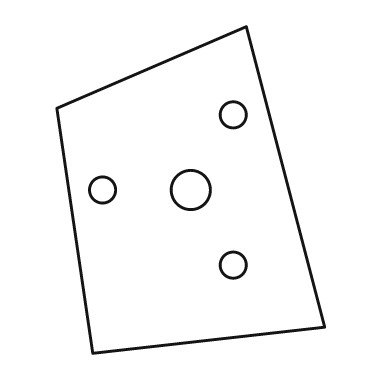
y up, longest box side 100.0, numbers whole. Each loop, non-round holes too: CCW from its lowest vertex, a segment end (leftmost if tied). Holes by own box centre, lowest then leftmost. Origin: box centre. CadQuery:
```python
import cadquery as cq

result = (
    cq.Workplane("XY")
    .moveTo(-30.0, -50.0)
    .lineTo(41.0, -42.0)
    .lineTo(17.0, 50.0)
    .lineTo(-41.0, 25.0)
    .close()
    .moveTo(13.0, -23.0)
    .circle(4.0)
    .moveTo(-27.0, 0.0)
    .circle(4.0)
    .moveTo(0.0, 0.0)
    .circle(6.0)
    .moveTo(13.0, 23.0)
    .circle(4.0)
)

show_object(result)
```